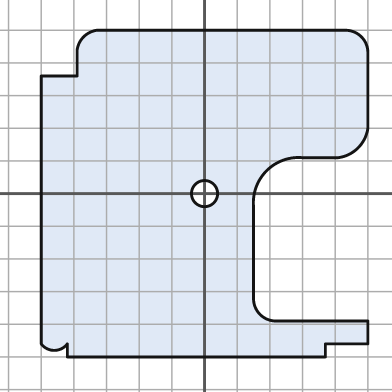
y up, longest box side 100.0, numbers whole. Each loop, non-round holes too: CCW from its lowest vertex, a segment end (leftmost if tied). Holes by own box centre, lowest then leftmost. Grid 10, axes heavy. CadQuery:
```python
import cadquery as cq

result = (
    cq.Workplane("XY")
    .moveTo(-42.0, -50.0)
    .lineTo(37.0, -50.0)
    .lineTo(37.0, -46.0)
    .lineTo(50.0, -46.0)
    .lineTo(50.0, -39.0)
    .lineTo(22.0, -39.0)
    .threePointArc((17.0, -37.0), (15.0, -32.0))
    .lineTo(15.0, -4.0)
    .threePointArc((19.0, 7.0), (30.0, 11.0))
    .lineTo(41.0, 11.0)
    .threePointArc((47.0, 14.0), (50.0, 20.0))
    .lineTo(50.0, 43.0)
    .threePointArc((48.0, 48.0), (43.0, 50.0))
    .lineTo(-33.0, 50.0)
    .threePointArc((-37.0, 48.0), (-39.0, 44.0))
    .lineTo(-39.0, 36.0)
    .lineTo(-50.0, 36.0)
    .lineTo(-50.0, -46.0)
    .threePointArc((-46.0, -48.0), (-42.0, -46.0))
    .close()
    .moveTo(0.0, 0.0)
    .circle(4.0)
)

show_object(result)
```